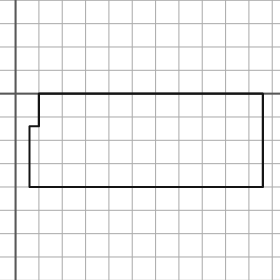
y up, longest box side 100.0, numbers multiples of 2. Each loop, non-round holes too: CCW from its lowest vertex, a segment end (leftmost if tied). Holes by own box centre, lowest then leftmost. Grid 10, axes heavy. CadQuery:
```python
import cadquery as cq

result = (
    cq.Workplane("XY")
    .moveTo(6.0, -40.0)
    .lineTo(106.0, -40.0)
    .lineTo(106.0, 0.0)
    .lineTo(10.0, 0.0)
    .lineTo(10.0, -14.0)
    .lineTo(6.0, -14.0)
    .close()
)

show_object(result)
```